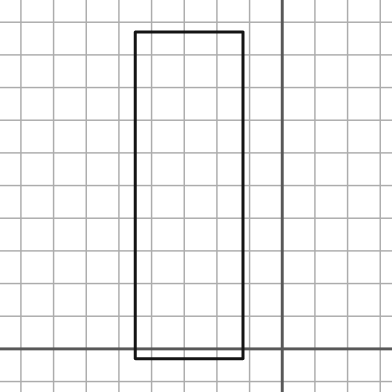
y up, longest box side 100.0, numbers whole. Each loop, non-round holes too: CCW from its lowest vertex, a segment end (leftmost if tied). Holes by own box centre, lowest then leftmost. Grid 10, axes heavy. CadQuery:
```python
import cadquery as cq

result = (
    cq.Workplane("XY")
    .moveTo(-45.0, -3.0)
    .lineTo(-12.0, -3.0)
    .lineTo(-12.0, 97.0)
    .lineTo(-45.0, 97.0)
    .close()
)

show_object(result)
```